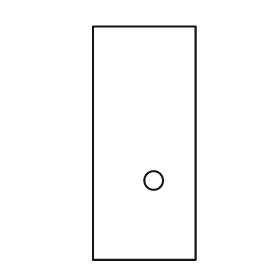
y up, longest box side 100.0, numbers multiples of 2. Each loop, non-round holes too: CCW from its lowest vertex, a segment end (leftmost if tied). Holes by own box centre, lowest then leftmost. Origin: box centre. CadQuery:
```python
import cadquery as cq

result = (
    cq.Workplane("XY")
    .moveTo(-22.0, -50.0)
    .lineTo(22.0, -50.0)
    .lineTo(22.0, 50.0)
    .lineTo(-22.0, 50.0)
    .close()
    .moveTo(4.0, -16.0)
    .circle(4.0)
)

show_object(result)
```